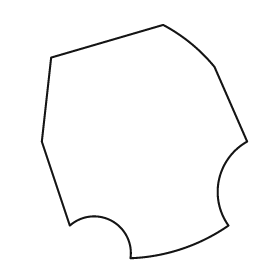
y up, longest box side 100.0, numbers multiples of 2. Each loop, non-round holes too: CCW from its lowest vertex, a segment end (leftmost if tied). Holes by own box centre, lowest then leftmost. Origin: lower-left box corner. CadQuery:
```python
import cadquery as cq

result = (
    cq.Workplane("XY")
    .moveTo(38.0, 0.0)
    .threePointArc((60.0, 4.0), (80.0, 14.0))
    .threePointArc((76.0, 34.0), (88.0, 50.0))
    .lineTo(74.0, 82.0)
    .threePointArc((64.0, 92.0), (52.0, 100.0))
    .lineTo(4.0, 86.0)
    .lineTo(0.0, 50.0)
    .lineTo(12.0, 14.0)
    .threePointArc((30.0, 16.0), (38.0, 0.0))
    .close()
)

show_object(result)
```